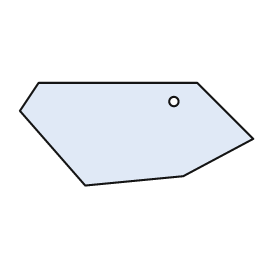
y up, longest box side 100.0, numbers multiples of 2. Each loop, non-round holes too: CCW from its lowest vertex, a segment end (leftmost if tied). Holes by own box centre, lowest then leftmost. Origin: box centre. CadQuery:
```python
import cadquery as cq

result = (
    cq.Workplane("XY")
    .moveTo(-22.0, -22.0)
    .lineTo(20.0, -18.0)
    .lineTo(50.0, -2.0)
    .lineTo(26.0, 22.0)
    .lineTo(-42.0, 22.0)
    .lineTo(-50.0, 10.0)
    .close()
    .moveTo(16.0, 14.0)
    .circle(2.0)
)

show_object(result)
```